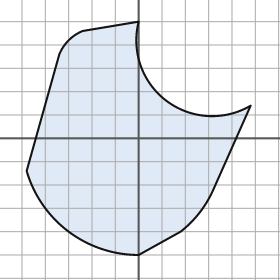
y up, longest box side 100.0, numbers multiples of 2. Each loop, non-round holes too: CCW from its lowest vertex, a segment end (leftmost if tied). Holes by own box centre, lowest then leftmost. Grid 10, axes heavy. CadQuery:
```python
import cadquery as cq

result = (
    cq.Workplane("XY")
    .moveTo(0.0, -50.0)
    .lineTo(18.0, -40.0)
    .threePointArc((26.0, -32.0), (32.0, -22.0))
    .lineTo(48.0, 14.0)
    .threePointArc((12.0, 16.0), (0.0, 50.0))
    .lineTo(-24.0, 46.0)
    .threePointArc((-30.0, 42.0), (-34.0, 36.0))
    .lineTo(-48.0, -14.0)
    .threePointArc((-30.0, -40.0), (0.0, -50.0))
    .close()
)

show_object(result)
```